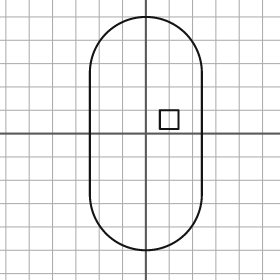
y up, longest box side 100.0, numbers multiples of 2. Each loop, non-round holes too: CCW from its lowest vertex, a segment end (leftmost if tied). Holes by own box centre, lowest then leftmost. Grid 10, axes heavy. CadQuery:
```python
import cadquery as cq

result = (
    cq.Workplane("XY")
    .moveTo(-24.0, -26.0)
    .threePointArc((0.0, -50.0), (24.0, -26.0))
    .lineTo(24.0, 26.0)
    .threePointArc((0.0, 50.0), (-24.0, 26.0))
    .close()
    .moveTo(6.0, 2.0)
    .lineTo(14.0, 2.0)
    .lineTo(14.0, 10.0)
    .lineTo(6.0, 10.0)
    .close()
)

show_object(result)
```